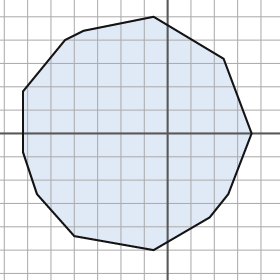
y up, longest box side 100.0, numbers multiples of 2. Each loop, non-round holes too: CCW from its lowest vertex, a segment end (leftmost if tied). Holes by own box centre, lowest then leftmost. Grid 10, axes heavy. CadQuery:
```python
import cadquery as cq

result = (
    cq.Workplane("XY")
    .moveTo(-6.0, -50.0)
    .lineTo(18.0, -36.0)
    .lineTo(26.0, -26.0)
    .lineTo(36.0, 0.0)
    .lineTo(24.0, 32.0)
    .lineTo(-6.0, 50.0)
    .lineTo(-36.0, 44.0)
    .lineTo(-44.0, 40.0)
    .lineTo(-62.0, 18.0)
    .lineTo(-62.0, -8.0)
    .lineTo(-56.0, -26.0)
    .lineTo(-40.0, -44.0)
    .close()
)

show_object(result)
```